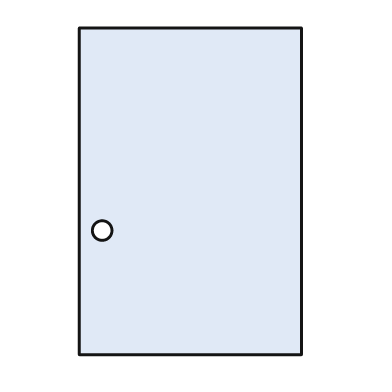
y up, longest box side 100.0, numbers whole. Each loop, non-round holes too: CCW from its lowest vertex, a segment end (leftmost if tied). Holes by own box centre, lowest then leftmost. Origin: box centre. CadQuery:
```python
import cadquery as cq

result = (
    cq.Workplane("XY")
    .moveTo(-34.0, -50.0)
    .lineTo(34.0, -50.0)
    .lineTo(34.0, 50.0)
    .lineTo(-34.0, 50.0)
    .close()
    .moveTo(-27.0, -12.0)
    .circle(3.0)
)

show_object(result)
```